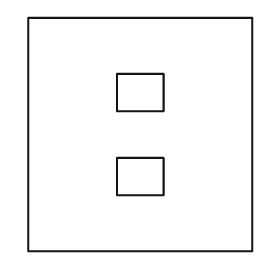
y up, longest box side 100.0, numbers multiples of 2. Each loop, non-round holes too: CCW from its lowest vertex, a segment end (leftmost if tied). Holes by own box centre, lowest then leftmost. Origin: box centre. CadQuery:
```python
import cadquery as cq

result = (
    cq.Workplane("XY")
    .moveTo(-48.0, -50.0)
    .lineTo(48.0, -50.0)
    .lineTo(48.0, 50.0)
    .lineTo(-48.0, 50.0)
    .close()
    .moveTo(-10.0, -26.0)
    .lineTo(10.0, -26.0)
    .lineTo(10.0, -10.0)
    .lineTo(-10.0, -10.0)
    .close()
    .moveTo(-10.0, 10.0)
    .lineTo(10.0, 10.0)
    .lineTo(10.0, 26.0)
    .lineTo(-10.0, 26.0)
    .close()
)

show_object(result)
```